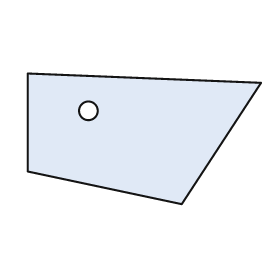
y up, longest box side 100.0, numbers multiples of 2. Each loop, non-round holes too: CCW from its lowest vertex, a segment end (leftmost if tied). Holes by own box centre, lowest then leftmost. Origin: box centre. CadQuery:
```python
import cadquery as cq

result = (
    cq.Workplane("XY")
    .moveTo(16.0, -28.0)
    .lineTo(50.0, 24.0)
    .lineTo(-50.0, 28.0)
    .lineTo(-50.0, -14.0)
    .close()
    .moveTo(-24.0, 12.0)
    .circle(4.0)
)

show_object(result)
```